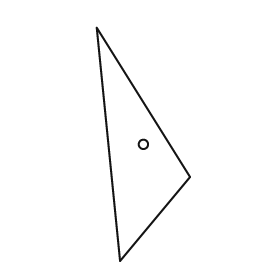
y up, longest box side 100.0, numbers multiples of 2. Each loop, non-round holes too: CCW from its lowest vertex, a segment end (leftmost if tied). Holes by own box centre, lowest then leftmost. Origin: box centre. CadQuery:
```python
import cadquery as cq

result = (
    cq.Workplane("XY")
    .moveTo(-10.0, -50.0)
    .lineTo(20.0, -14.0)
    .lineTo(-20.0, 50.0)
    .close()
    .moveTo(0.0, 0.0)
    .circle(2.0)
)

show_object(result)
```